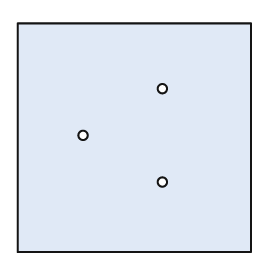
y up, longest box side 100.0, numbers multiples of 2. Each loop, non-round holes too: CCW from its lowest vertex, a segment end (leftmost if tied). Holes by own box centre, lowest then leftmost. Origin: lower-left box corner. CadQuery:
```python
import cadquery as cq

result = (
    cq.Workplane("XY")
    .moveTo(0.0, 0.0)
    .lineTo(100.0, 0.0)
    .lineTo(100.0, 98.0)
    .lineTo(0.0, 98.0)
    .close()
    .moveTo(62.0, 30.0)
    .circle(2.0)
    .moveTo(28.0, 50.0)
    .circle(2.0)
    .moveTo(62.0, 70.0)
    .circle(2.0)
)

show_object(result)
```